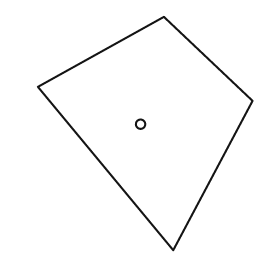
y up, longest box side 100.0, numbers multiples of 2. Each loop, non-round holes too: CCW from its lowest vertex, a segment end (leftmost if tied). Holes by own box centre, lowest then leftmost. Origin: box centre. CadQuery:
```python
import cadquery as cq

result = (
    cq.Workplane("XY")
    .moveTo(12.0, -50.0)
    .lineTo(46.0, 14.0)
    .lineTo(8.0, 50.0)
    .lineTo(-46.0, 20.0)
    .close()
    .moveTo(-2.0, 4.0)
    .circle(2.0)
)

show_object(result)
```